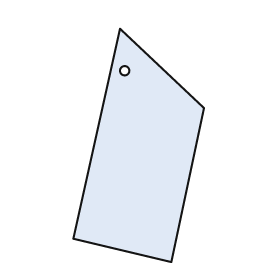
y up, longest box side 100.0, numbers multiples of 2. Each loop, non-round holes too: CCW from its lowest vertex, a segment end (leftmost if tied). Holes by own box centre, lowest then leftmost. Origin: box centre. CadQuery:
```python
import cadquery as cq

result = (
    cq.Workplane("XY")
    .moveTo(14.0, -50.0)
    .lineTo(28.0, 16.0)
    .lineTo(-8.0, 50.0)
    .lineTo(-28.0, -40.0)
    .close()
    .moveTo(-6.0, 32.0)
    .circle(2.0)
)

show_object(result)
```